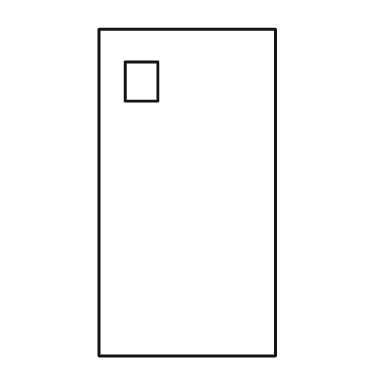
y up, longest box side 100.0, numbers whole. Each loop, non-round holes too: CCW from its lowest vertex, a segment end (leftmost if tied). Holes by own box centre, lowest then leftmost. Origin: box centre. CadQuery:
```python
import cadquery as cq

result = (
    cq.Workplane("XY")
    .moveTo(-27.0, -50.0)
    .lineTo(27.0, -50.0)
    .lineTo(27.0, 50.0)
    .lineTo(-27.0, 50.0)
    .close()
    .moveTo(-19.0, 28.0)
    .lineTo(-9.0, 28.0)
    .lineTo(-9.0, 40.0)
    .lineTo(-19.0, 40.0)
    .close()
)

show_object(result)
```